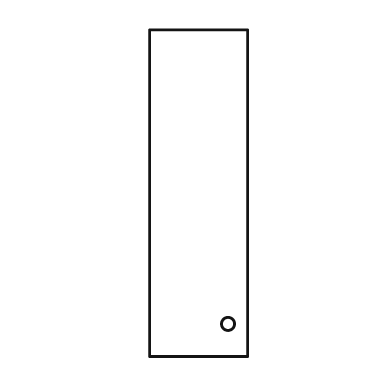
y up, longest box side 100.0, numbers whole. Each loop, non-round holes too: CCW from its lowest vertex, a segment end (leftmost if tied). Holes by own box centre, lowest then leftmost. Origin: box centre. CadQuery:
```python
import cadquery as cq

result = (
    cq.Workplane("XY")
    .moveTo(-15.0, -50.0)
    .lineTo(15.0, -50.0)
    .lineTo(15.0, 50.0)
    .lineTo(-15.0, 50.0)
    .close()
    .moveTo(9.0, -40.0)
    .circle(2.0)
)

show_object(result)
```